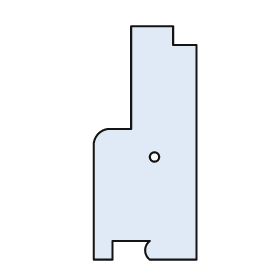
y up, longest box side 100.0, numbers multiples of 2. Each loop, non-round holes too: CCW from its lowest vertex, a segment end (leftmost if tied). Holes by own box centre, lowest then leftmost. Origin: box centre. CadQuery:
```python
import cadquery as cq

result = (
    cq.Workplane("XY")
    .moveTo(-22.0, -50.0)
    .lineTo(-14.0, -50.0)
    .lineTo(-14.0, -42.0)
    .lineTo(2.0, -42.0)
    .threePointArc((0.0, -46.0), (2.0, -50.0))
    .lineTo(22.0, -50.0)
    .lineTo(22.0, 42.0)
    .lineTo(12.0, 42.0)
    .lineTo(12.0, 50.0)
    .lineTo(-6.0, 50.0)
    .lineTo(-6.0, 6.0)
    .lineTo(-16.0, 6.0)
    .threePointArc((-20.0, 4.0), (-22.0, 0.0))
    .close()
    .moveTo(4.0, -6.0)
    .circle(2.0)
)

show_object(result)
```